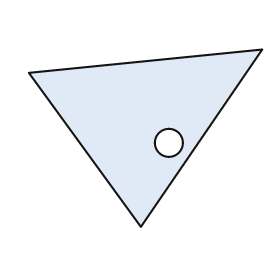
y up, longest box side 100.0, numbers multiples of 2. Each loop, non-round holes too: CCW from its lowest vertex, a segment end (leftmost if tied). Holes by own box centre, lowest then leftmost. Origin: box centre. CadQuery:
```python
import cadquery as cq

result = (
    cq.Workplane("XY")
    .moveTo(-2.0, -38.0)
    .lineTo(50.0, 38.0)
    .lineTo(-50.0, 28.0)
    .close()
    .moveTo(10.0, -2.0)
    .circle(6.0)
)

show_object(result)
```